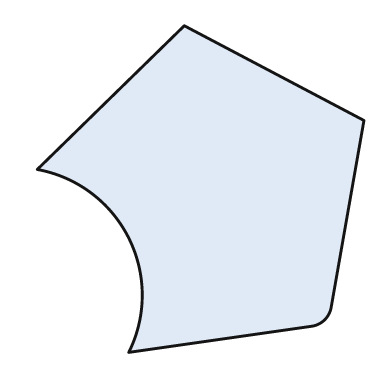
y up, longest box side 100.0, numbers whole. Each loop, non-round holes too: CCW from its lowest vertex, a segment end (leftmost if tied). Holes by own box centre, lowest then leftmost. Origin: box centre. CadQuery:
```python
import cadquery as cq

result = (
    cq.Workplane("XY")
    .moveTo(-22.0, -50.0)
    .lineTo(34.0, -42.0)
    .threePointArc((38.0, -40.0), (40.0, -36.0))
    .lineTo(50.0, 21.0)
    .lineTo(-5.0, 50.0)
    .lineTo(-50.0, 6.0)
    .threePointArc((-22.0, -15.0), (-22.0, -50.0))
    .close()
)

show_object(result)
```